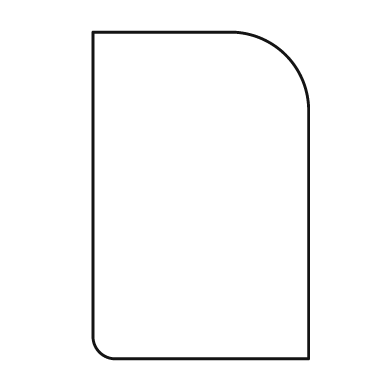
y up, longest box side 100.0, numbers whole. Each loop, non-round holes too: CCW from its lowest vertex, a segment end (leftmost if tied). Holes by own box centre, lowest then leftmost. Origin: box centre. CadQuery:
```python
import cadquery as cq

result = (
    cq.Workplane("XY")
    .moveTo(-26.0, -50.0)
    .lineTo(33.0, -50.0)
    .lineTo(33.0, 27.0)
    .threePointArc((26.0, 43.0), (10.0, 50.0))
    .lineTo(-33.0, 50.0)
    .lineTo(-33.0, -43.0)
    .threePointArc((-31.0, -48.0), (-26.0, -50.0))
    .close()
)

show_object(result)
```